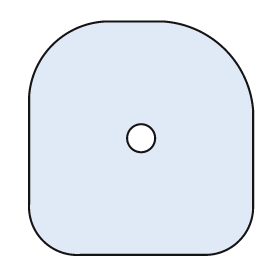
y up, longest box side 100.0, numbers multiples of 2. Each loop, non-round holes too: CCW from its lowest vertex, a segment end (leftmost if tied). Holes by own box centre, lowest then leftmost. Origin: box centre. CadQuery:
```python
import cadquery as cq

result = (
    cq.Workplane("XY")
    .moveTo(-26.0, -50.0)
    .lineTo(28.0, -50.0)
    .threePointArc((42.0, -44.0), (48.0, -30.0))
    .lineTo(48.0, 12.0)
    .threePointArc((36.0, 38.0), (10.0, 50.0))
    .lineTo(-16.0, 50.0)
    .threePointArc((-38.0, 40.0), (-48.0, 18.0))
    .lineTo(-48.0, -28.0)
    .threePointArc((-42.0, -44.0), (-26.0, -50.0))
    .close()
    .moveTo(0.0, 0.0)
    .circle(6.0)
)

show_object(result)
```